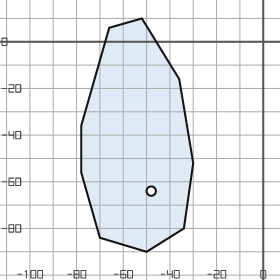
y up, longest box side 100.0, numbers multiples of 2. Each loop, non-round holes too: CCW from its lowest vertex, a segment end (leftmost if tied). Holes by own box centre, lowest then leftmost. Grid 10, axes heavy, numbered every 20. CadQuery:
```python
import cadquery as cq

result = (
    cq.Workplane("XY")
    .moveTo(-50.0, -90.0)
    .lineTo(-34.0, -80.0)
    .lineTo(-30.0, -52.0)
    .lineTo(-36.0, -16.0)
    .lineTo(-52.0, 10.0)
    .lineTo(-66.0, 6.0)
    .lineTo(-78.0, -36.0)
    .lineTo(-78.0, -56.0)
    .lineTo(-70.0, -84.0)
    .close()
    .moveTo(-48.0, -64.0)
    .circle(2.0)
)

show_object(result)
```